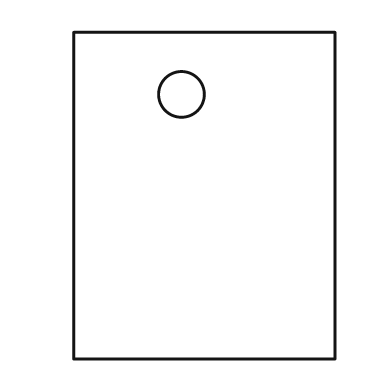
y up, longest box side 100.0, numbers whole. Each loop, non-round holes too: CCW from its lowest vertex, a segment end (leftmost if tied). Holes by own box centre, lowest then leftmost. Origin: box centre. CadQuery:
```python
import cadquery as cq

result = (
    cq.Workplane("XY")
    .moveTo(-40.0, -50.0)
    .lineTo(40.0, -50.0)
    .lineTo(40.0, 50.0)
    .lineTo(-40.0, 50.0)
    .close()
    .moveTo(-7.0, 31.0)
    .circle(7.0)
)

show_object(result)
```